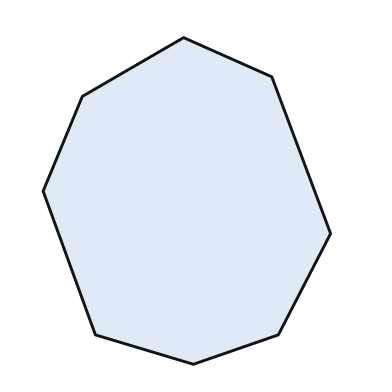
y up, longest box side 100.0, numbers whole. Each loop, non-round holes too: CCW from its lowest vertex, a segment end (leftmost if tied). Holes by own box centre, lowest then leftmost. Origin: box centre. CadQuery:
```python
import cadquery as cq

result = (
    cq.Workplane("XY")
    .moveTo(2.0, -50.0)
    .lineTo(28.0, -41.0)
    .lineTo(44.0, -10.0)
    .lineTo(26.0, 38.0)
    .lineTo(-1.0, 50.0)
    .lineTo(-32.0, 32.0)
    .lineTo(-44.0, 3.0)
    .lineTo(-28.0, -41.0)
    .close()
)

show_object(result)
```